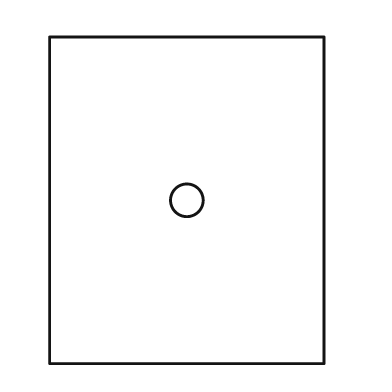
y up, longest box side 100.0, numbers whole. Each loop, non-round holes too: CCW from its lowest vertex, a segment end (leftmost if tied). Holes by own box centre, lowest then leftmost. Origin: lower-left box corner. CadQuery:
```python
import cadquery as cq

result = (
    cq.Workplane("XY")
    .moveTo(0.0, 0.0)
    .lineTo(84.0, 0.0)
    .lineTo(84.0, 100.0)
    .lineTo(0.0, 100.0)
    .close()
    .moveTo(42.0, 50.0)
    .circle(5.0)
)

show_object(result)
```